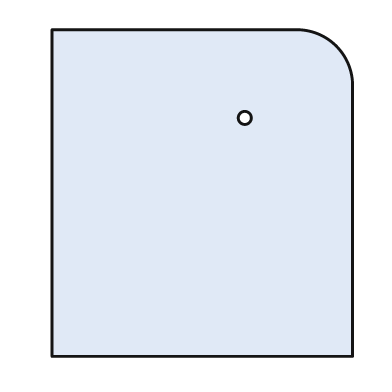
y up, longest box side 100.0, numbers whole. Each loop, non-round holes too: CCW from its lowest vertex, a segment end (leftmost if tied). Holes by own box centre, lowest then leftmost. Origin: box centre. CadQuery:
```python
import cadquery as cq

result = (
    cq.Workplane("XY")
    .moveTo(-46.0, -50.0)
    .lineTo(46.0, -50.0)
    .lineTo(46.0, 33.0)
    .threePointArc((41.0, 45.0), (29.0, 50.0))
    .lineTo(-46.0, 50.0)
    .close()
    .moveTo(13.0, 23.0)
    .circle(2.0)
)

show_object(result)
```